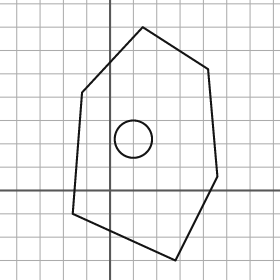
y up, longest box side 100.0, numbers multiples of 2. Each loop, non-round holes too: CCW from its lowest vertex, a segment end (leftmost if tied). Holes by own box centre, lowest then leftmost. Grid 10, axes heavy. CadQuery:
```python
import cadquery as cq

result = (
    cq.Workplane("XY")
    .moveTo(28.0, -30.0)
    .lineTo(46.0, 6.0)
    .lineTo(42.0, 52.0)
    .lineTo(14.0, 70.0)
    .lineTo(-12.0, 42.0)
    .lineTo(-16.0, -10.0)
    .close()
    .moveTo(10.0, 22.0)
    .circle(8.0)
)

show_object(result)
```